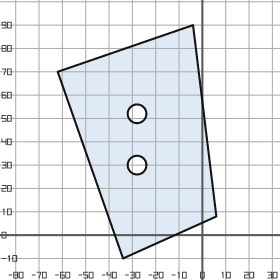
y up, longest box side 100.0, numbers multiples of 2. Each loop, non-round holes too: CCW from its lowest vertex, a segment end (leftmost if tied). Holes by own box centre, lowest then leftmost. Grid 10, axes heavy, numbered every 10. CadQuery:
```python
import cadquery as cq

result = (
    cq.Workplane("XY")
    .moveTo(-34.0, -10.0)
    .lineTo(6.0, 8.0)
    .lineTo(-4.0, 90.0)
    .lineTo(-62.0, 70.0)
    .close()
    .moveTo(-28.0, 30.0)
    .circle(4.0)
    .moveTo(-28.0, 52.0)
    .circle(4.0)
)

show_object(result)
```